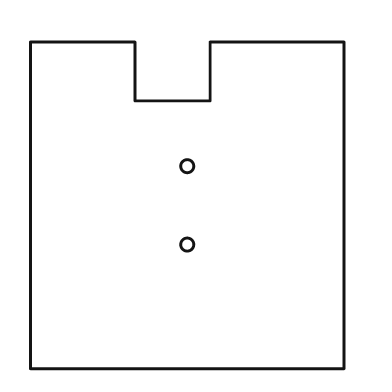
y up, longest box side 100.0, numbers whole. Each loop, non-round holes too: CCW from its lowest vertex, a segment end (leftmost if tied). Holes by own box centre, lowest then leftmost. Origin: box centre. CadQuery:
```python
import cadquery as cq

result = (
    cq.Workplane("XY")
    .moveTo(-48.0, -50.0)
    .lineTo(48.0, -50.0)
    .lineTo(48.0, 50.0)
    .lineTo(7.0, 50.0)
    .lineTo(7.0, 32.0)
    .lineTo(-16.0, 32.0)
    .lineTo(-16.0, 50.0)
    .lineTo(-48.0, 50.0)
    .close()
    .moveTo(0.0, -12.0)
    .circle(2.0)
    .moveTo(0.0, 12.0)
    .circle(2.0)
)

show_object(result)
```